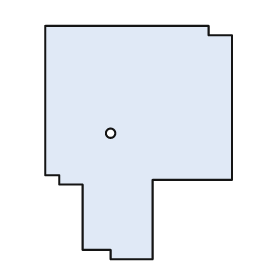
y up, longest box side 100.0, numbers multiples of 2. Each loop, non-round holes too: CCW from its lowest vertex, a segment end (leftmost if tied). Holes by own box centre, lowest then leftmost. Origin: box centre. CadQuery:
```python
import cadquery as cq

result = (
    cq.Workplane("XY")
    .moveTo(-12.0, -50.0)
    .lineTo(6.0, -50.0)
    .lineTo(6.0, -16.0)
    .lineTo(40.0, -16.0)
    .lineTo(40.0, 46.0)
    .lineTo(30.0, 46.0)
    .lineTo(30.0, 50.0)
    .lineTo(-40.0, 50.0)
    .lineTo(-40.0, -14.0)
    .lineTo(-34.0, -14.0)
    .lineTo(-34.0, -18.0)
    .lineTo(-24.0, -18.0)
    .lineTo(-24.0, -46.0)
    .lineTo(-12.0, -46.0)
    .close()
    .moveTo(-12.0, 4.0)
    .circle(2.0)
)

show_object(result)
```